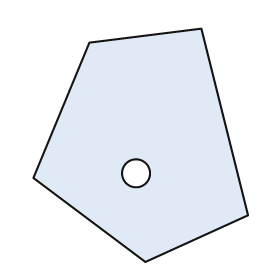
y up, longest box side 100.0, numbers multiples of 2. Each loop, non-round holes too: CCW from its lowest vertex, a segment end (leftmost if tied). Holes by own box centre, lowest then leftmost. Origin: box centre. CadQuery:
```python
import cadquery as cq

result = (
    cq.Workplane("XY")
    .moveTo(2.0, -50.0)
    .lineTo(46.0, -30.0)
    .lineTo(26.0, 50.0)
    .lineTo(-22.0, 44.0)
    .lineTo(-46.0, -14.0)
    .close()
    .moveTo(-2.0, -12.0)
    .circle(6.0)
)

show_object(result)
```